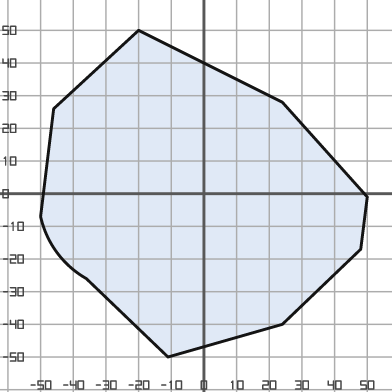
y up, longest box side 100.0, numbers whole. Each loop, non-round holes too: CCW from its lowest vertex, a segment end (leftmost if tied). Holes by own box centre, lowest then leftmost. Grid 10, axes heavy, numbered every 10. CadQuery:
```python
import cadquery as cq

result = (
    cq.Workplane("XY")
    .moveTo(-11.0, -50.0)
    .lineTo(24.0, -40.0)
    .lineTo(48.0, -17.0)
    .lineTo(50.0, -1.0)
    .lineTo(24.0, 28.0)
    .lineTo(-20.0, 50.0)
    .lineTo(-46.0, 26.0)
    .lineTo(-50.0, -7.0)
    .threePointArc((-45.0, -18.0), (-36.0, -26.0))
    .close()
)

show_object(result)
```